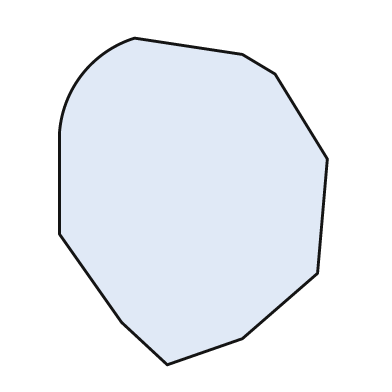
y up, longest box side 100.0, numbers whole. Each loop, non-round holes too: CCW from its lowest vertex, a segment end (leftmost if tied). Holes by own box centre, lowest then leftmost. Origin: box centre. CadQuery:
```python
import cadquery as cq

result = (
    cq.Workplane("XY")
    .moveTo(-8.0, -50.0)
    .lineTo(15.0, -42.0)
    .lineTo(38.0, -22.0)
    .lineTo(41.0, 13.0)
    .lineTo(25.0, 39.0)
    .lineTo(15.0, 45.0)
    .lineTo(-18.0, 50.0)
    .threePointArc((-34.0, 39.0), (-41.0, 21.0))
    .lineTo(-41.0, -10.0)
    .lineTo(-22.0, -37.0)
    .close()
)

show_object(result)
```